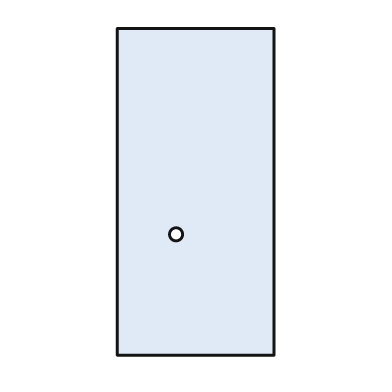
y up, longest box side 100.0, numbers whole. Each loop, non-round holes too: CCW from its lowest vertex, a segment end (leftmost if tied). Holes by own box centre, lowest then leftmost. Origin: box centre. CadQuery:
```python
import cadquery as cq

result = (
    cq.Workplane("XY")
    .moveTo(-24.0, -50.0)
    .lineTo(24.0, -50.0)
    .lineTo(24.0, 50.0)
    .lineTo(-24.0, 50.0)
    .close()
    .moveTo(-6.0, -13.0)
    .circle(2.0)
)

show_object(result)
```